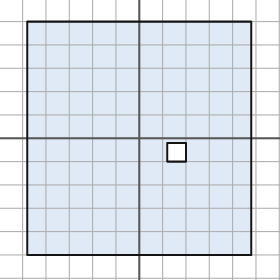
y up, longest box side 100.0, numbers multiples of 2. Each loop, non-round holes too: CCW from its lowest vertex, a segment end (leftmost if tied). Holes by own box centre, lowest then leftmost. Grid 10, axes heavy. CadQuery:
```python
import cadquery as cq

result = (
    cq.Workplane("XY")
    .moveTo(-48.0, -50.0)
    .lineTo(48.0, -50.0)
    .lineTo(48.0, 50.0)
    .lineTo(-48.0, 50.0)
    .close()
    .moveTo(12.0, -10.0)
    .lineTo(20.0, -10.0)
    .lineTo(20.0, -2.0)
    .lineTo(12.0, -2.0)
    .close()
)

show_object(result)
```